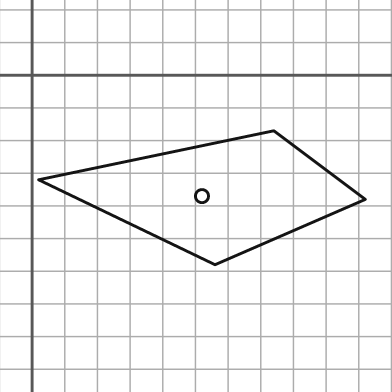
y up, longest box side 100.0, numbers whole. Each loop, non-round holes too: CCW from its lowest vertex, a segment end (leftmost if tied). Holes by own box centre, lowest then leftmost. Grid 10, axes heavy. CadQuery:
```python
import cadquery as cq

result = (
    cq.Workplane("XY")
    .moveTo(56.0, -58.0)
    .lineTo(102.0, -38.0)
    .lineTo(74.0, -17.0)
    .lineTo(2.0, -32.0)
    .close()
    .moveTo(52.0, -37.0)
    .circle(2.0)
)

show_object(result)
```